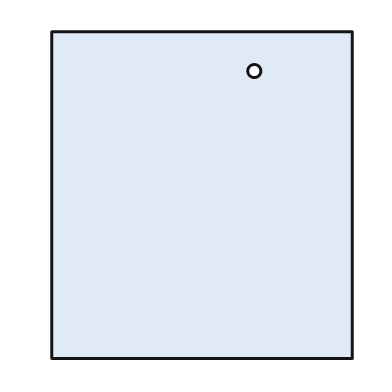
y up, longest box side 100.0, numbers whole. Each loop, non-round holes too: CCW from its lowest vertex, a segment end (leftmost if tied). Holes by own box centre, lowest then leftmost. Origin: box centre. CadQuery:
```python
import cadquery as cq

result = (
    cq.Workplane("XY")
    .moveTo(-46.0, -50.0)
    .lineTo(46.0, -50.0)
    .lineTo(46.0, 50.0)
    .lineTo(-46.0, 50.0)
    .close()
    .moveTo(16.0, 38.0)
    .circle(2.0)
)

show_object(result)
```